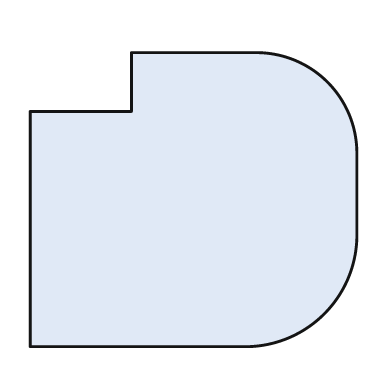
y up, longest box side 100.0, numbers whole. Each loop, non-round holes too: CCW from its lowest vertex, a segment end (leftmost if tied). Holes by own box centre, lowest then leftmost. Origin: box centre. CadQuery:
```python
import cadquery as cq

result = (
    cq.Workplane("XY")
    .moveTo(-50.0, -45.0)
    .lineTo(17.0, -45.0)
    .threePointArc((40.0, -35.0), (50.0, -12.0))
    .lineTo(50.0, 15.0)
    .threePointArc((41.0, 36.0), (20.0, 45.0))
    .lineTo(-19.0, 45.0)
    .lineTo(-19.0, 27.0)
    .lineTo(-50.0, 27.0)
    .close()
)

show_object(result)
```